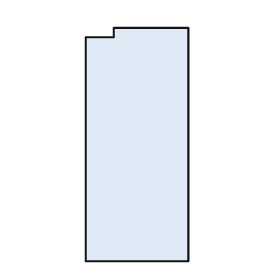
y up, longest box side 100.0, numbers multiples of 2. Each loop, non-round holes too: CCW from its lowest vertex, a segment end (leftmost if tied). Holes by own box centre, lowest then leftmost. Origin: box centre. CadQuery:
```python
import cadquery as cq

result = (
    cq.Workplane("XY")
    .moveTo(-22.0, -50.0)
    .lineTo(22.0, -50.0)
    .lineTo(22.0, 50.0)
    .lineTo(-10.0, 50.0)
    .lineTo(-10.0, 46.0)
    .lineTo(-22.0, 46.0)
    .close()
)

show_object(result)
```